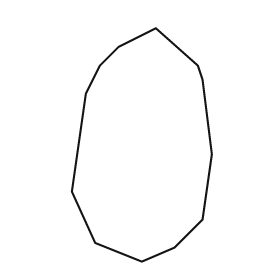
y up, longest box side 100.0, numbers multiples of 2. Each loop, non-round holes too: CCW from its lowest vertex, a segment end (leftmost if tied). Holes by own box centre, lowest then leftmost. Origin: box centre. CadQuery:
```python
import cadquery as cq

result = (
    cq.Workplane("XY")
    .moveTo(0.0, -50.0)
    .lineTo(14.0, -44.0)
    .lineTo(26.0, -32.0)
    .lineTo(30.0, -4.0)
    .lineTo(26.0, 28.0)
    .lineTo(24.0, 34.0)
    .lineTo(6.0, 50.0)
    .lineTo(-10.0, 42.0)
    .lineTo(-18.0, 34.0)
    .lineTo(-24.0, 22.0)
    .lineTo(-30.0, -20.0)
    .lineTo(-20.0, -42.0)
    .close()
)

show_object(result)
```